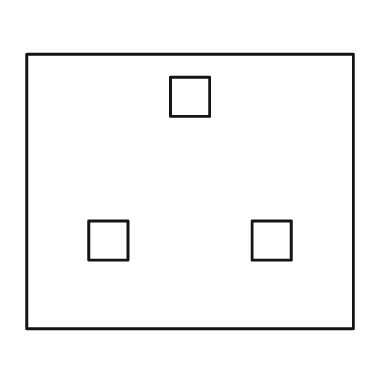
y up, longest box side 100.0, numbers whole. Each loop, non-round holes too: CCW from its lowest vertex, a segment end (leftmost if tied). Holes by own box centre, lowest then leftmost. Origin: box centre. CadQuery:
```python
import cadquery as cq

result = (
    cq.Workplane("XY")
    .moveTo(-50.0, -42.0)
    .lineTo(50.0, -42.0)
    .lineTo(50.0, 42.0)
    .lineTo(-50.0, 42.0)
    .close()
    .moveTo(-31.0, -21.0)
    .lineTo(-19.0, -21.0)
    .lineTo(-19.0, -9.0)
    .lineTo(-31.0, -9.0)
    .close()
    .moveTo(19.0, -21.0)
    .lineTo(31.0, -21.0)
    .lineTo(31.0, -9.0)
    .lineTo(19.0, -9.0)
    .close()
    .moveTo(-6.0, 23.0)
    .lineTo(6.0, 23.0)
    .lineTo(6.0, 35.0)
    .lineTo(-6.0, 35.0)
    .close()
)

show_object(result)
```